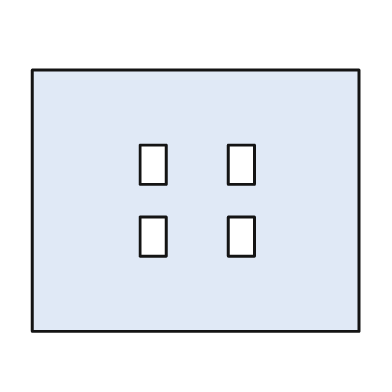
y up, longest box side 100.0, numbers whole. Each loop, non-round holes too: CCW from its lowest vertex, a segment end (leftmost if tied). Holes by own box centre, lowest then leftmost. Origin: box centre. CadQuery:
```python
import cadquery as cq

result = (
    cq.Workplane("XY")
    .moveTo(-50.0, -40.0)
    .lineTo(50.0, -40.0)
    .lineTo(50.0, 40.0)
    .lineTo(-50.0, 40.0)
    .close()
    .moveTo(-17.0, -17.0)
    .lineTo(-9.0, -17.0)
    .lineTo(-9.0, -5.0)
    .lineTo(-17.0, -5.0)
    .close()
    .moveTo(10.0, -17.0)
    .lineTo(18.0, -17.0)
    .lineTo(18.0, -5.0)
    .lineTo(10.0, -5.0)
    .close()
    .moveTo(-17.0, 5.0)
    .lineTo(-9.0, 5.0)
    .lineTo(-9.0, 17.0)
    .lineTo(-17.0, 17.0)
    .close()
    .moveTo(10.0, 5.0)
    .lineTo(18.0, 5.0)
    .lineTo(18.0, 17.0)
    .lineTo(10.0, 17.0)
    .close()
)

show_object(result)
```